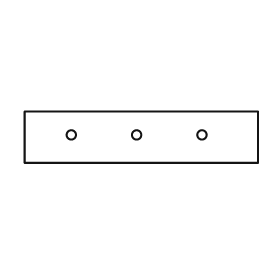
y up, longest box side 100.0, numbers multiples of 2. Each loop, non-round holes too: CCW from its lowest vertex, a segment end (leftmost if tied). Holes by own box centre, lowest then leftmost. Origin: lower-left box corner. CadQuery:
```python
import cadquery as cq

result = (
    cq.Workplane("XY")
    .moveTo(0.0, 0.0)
    .lineTo(100.0, 0.0)
    .lineTo(100.0, 22.0)
    .lineTo(0.0, 22.0)
    .close()
    .moveTo(20.0, 12.0)
    .circle(2.0)
    .moveTo(48.0, 12.0)
    .circle(2.0)
    .moveTo(76.0, 12.0)
    .circle(2.0)
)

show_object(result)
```